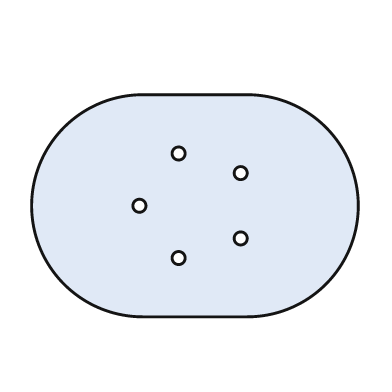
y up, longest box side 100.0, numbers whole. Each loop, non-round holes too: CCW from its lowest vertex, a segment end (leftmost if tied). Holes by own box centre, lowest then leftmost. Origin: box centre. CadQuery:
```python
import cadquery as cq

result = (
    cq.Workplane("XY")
    .moveTo(-16.0, -34.0)
    .lineTo(16.0, -34.0)
    .threePointArc((50.0, 0.0), (16.0, 34.0))
    .lineTo(-16.0, 34.0)
    .threePointArc((-50.0, 0.0), (-16.0, -34.0))
    .close()
    .moveTo(-5.0, -16.0)
    .circle(2.0)
    .moveTo(14.0, -10.0)
    .circle(2.0)
    .moveTo(-17.0, 0.0)
    .circle(2.0)
    .moveTo(14.0, 10.0)
    .circle(2.0)
    .moveTo(-5.0, 16.0)
    .circle(2.0)
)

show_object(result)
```